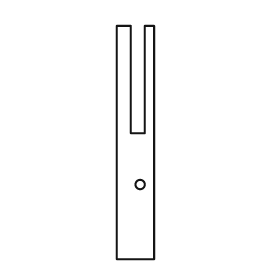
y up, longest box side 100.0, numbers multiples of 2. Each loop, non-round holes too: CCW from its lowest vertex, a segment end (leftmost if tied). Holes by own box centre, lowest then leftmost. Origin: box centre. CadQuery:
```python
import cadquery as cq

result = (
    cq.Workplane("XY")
    .moveTo(-8.0, -50.0)
    .lineTo(8.0, -50.0)
    .lineTo(8.0, 50.0)
    .lineTo(4.0, 50.0)
    .lineTo(4.0, 4.0)
    .lineTo(-2.0, 4.0)
    .lineTo(-2.0, 50.0)
    .lineTo(-8.0, 50.0)
    .close()
    .moveTo(2.0, -18.0)
    .circle(2.0)
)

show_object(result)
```